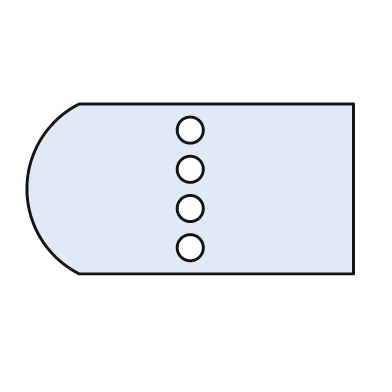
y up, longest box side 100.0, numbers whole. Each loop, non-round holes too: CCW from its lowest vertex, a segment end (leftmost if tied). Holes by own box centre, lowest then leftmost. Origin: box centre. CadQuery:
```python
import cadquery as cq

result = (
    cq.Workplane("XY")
    .moveTo(-34.0, -26.0)
    .lineTo(50.0, -26.0)
    .lineTo(50.0, 26.0)
    .lineTo(-34.0, 26.0)
    .threePointArc((-50.0, 0.0), (-34.0, -26.0))
    .close()
    .moveTo(0.0, -18.0)
    .circle(4.0)
    .moveTo(0.0, -6.0)
    .circle(4.0)
    .moveTo(0.0, 6.0)
    .circle(4.0)
    .moveTo(0.0, 18.0)
    .circle(4.0)
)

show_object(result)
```